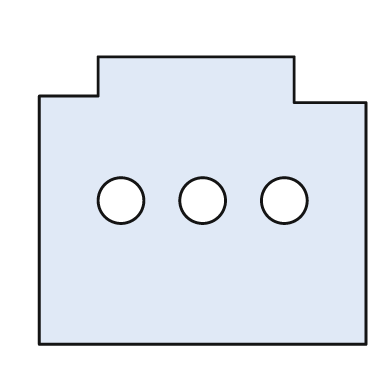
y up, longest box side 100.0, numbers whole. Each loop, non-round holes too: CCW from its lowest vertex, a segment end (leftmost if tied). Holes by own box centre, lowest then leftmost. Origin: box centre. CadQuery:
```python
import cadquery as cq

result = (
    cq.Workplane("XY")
    .moveTo(-50.0, -44.0)
    .lineTo(50.0, -44.0)
    .lineTo(50.0, 30.0)
    .lineTo(28.0, 30.0)
    .lineTo(28.0, 44.0)
    .lineTo(-32.0, 44.0)
    .lineTo(-32.0, 32.0)
    .lineTo(-50.0, 32.0)
    .close()
    .moveTo(-25.0, 0.0)
    .circle(7.0)
    .moveTo(0.0, 0.0)
    .circle(7.0)
    .moveTo(25.0, 0.0)
    .circle(7.0)
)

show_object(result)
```